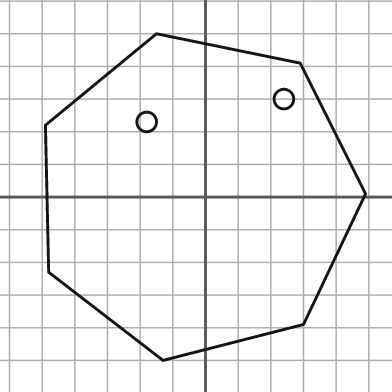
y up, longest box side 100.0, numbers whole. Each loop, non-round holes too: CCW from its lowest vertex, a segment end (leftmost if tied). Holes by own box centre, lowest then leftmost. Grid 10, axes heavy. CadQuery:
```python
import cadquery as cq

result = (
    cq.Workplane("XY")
    .moveTo(-13.0, -50.0)
    .lineTo(30.0, -39.0)
    .lineTo(49.0, 1.0)
    .lineTo(29.0, 41.0)
    .lineTo(-15.0, 50.0)
    .lineTo(-49.0, 22.0)
    .lineTo(-48.0, -23.0)
    .close()
    .moveTo(-18.0, 23.0)
    .circle(3.0)
    .moveTo(24.0, 30.0)
    .circle(3.0)
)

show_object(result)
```